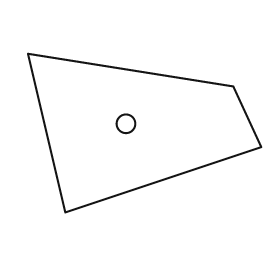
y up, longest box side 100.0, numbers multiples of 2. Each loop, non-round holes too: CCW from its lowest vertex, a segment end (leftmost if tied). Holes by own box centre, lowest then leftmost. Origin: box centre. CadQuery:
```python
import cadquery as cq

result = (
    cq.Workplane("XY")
    .moveTo(-34.0, -34.0)
    .lineTo(50.0, -6.0)
    .lineTo(38.0, 20.0)
    .lineTo(-50.0, 34.0)
    .close()
    .moveTo(-8.0, 4.0)
    .circle(4.0)
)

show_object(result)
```